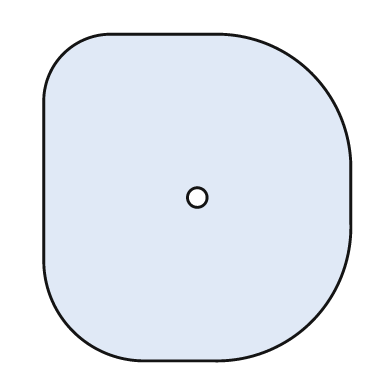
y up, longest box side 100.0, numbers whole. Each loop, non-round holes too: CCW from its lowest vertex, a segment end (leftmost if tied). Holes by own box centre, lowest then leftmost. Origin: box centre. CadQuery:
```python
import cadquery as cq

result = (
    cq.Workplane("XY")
    .moveTo(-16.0, -50.0)
    .lineTo(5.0, -50.0)
    .threePointArc((35.0, -38.0), (47.0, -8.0))
    .lineTo(47.0, 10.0)
    .threePointArc((35.0, 38.0), (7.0, 50.0))
    .lineTo(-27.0, 50.0)
    .threePointArc((-41.0, 44.0), (-47.0, 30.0))
    .lineTo(-47.0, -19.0)
    .threePointArc((-38.0, -41.0), (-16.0, -50.0))
    .close()
    .moveTo(0.0, 0.0)
    .circle(3.0)
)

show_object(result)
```